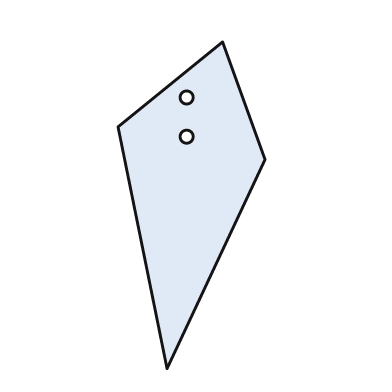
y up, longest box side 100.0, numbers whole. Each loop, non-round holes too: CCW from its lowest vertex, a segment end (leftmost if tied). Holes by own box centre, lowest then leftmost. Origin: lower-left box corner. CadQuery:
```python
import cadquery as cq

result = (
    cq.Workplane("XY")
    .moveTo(15.0, 0.0)
    .lineTo(45.0, 64.0)
    .lineTo(32.0, 100.0)
    .lineTo(0.0, 74.0)
    .close()
    .moveTo(21.0, 71.0)
    .circle(2.0)
    .moveTo(21.0, 83.0)
    .circle(2.0)
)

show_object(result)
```